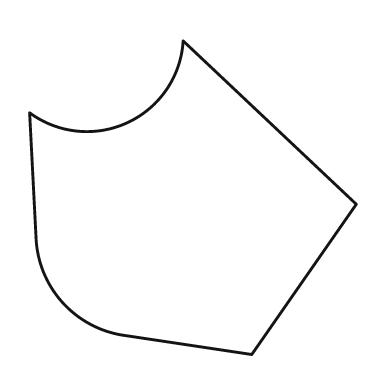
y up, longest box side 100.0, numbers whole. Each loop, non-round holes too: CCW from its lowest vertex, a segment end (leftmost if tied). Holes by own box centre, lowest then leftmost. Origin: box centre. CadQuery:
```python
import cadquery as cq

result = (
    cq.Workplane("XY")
    .moveTo(18.0, -48.0)
    .lineTo(50.0, -2.0)
    .lineTo(-3.0, 48.0)
    .threePointArc((-20.0, 23.0), (-50.0, 26.0))
    .lineTo(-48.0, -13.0)
    .threePointArc((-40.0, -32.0), (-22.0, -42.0))
    .close()
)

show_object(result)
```